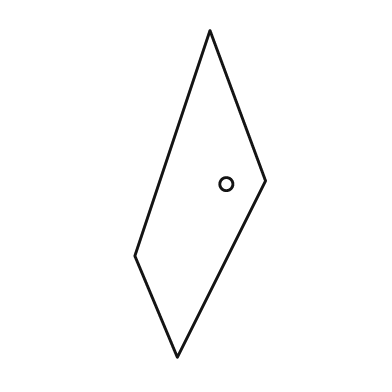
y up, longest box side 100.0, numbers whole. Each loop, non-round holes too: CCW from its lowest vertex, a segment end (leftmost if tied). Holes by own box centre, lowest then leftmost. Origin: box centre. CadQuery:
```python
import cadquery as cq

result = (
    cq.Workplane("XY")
    .moveTo(-7.0, -50.0)
    .lineTo(20.0, 4.0)
    .lineTo(3.0, 50.0)
    .lineTo(-20.0, -19.0)
    .close()
    .moveTo(8.0, 3.0)
    .circle(2.0)
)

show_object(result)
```